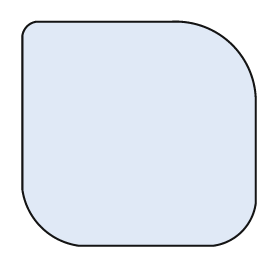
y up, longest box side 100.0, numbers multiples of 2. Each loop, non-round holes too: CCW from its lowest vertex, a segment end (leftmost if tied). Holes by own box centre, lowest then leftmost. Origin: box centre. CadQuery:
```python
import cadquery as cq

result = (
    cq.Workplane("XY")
    .moveTo(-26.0, -48.0)
    .lineTo(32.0, -48.0)
    .threePointArc((44.0, -42.0), (50.0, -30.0))
    .lineTo(50.0, 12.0)
    .threePointArc((40.0, 38.0), (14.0, 48.0))
    .lineTo(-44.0, 48.0)
    .threePointArc((-48.0, 46.0), (-50.0, 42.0))
    .lineTo(-50.0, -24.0)
    .threePointArc((-42.0, -40.0), (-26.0, -48.0))
    .close()
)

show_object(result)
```